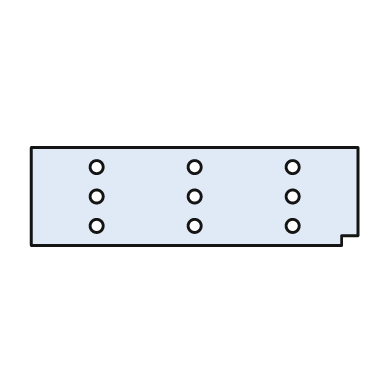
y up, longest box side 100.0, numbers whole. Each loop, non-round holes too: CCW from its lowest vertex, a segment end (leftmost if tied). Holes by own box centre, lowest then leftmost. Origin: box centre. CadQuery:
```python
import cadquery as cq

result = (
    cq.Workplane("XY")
    .moveTo(-50.0, -15.0)
    .lineTo(45.0, -15.0)
    .lineTo(45.0, -12.0)
    .lineTo(50.0, -12.0)
    .lineTo(50.0, 15.0)
    .lineTo(-50.0, 15.0)
    .close()
    .moveTo(-30.0, -9.0)
    .circle(2.0)
    .moveTo(0.0, -9.0)
    .circle(2.0)
    .moveTo(30.0, -9.0)
    .circle(2.0)
    .moveTo(-30.0, 0.0)
    .circle(2.0)
    .moveTo(0.0, 0.0)
    .circle(2.0)
    .moveTo(30.0, 0.0)
    .circle(2.0)
    .moveTo(-30.0, 9.0)
    .circle(2.0)
    .moveTo(0.0, 9.0)
    .circle(2.0)
    .moveTo(30.0, 9.0)
    .circle(2.0)
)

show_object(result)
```